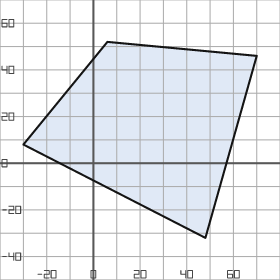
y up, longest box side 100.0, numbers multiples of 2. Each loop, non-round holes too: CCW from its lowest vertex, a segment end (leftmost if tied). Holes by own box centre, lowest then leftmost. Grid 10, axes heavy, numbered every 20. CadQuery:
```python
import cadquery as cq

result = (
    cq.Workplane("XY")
    .moveTo(48.0, -32.0)
    .lineTo(70.0, 46.0)
    .lineTo(6.0, 52.0)
    .lineTo(-30.0, 8.0)
    .close()
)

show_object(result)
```